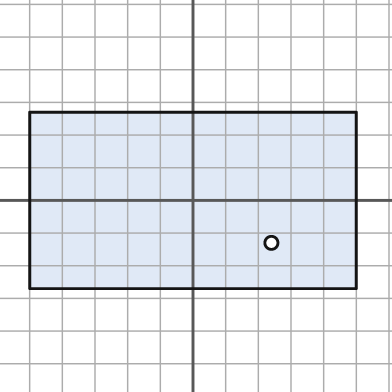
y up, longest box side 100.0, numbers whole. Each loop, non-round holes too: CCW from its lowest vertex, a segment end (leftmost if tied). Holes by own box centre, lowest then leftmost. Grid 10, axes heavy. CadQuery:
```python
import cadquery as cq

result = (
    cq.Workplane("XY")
    .moveTo(-50.0, -27.0)
    .lineTo(50.0, -27.0)
    .lineTo(50.0, 27.0)
    .lineTo(-50.0, 27.0)
    .close()
    .moveTo(24.0, -13.0)
    .circle(2.0)
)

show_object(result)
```